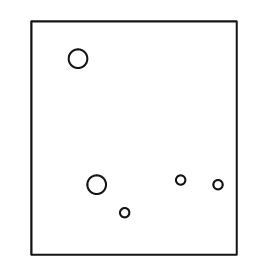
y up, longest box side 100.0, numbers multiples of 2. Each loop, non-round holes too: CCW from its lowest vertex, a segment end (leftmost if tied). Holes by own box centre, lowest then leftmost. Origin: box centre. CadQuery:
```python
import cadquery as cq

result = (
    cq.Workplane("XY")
    .moveTo(-44.0, -50.0)
    .lineTo(44.0, -50.0)
    .lineTo(44.0, 50.0)
    .lineTo(-44.0, 50.0)
    .close()
    .moveTo(-4.0, -32.0)
    .circle(2.0)
    .moveTo(-16.0, -20.0)
    .circle(4.0)
    .moveTo(36.0, -20.0)
    .circle(2.0)
    .moveTo(20.0, -18.0)
    .circle(2.0)
    .moveTo(-24.0, 34.0)
    .circle(4.0)
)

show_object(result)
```